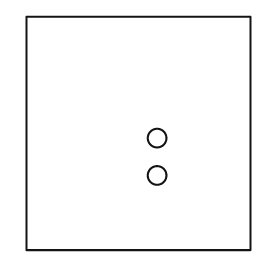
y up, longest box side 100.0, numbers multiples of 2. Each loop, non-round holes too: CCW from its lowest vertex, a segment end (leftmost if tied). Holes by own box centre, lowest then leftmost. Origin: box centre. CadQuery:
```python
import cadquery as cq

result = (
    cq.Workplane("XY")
    .moveTo(-48.0, -50.0)
    .lineTo(48.0, -50.0)
    .lineTo(48.0, 50.0)
    .lineTo(-48.0, 50.0)
    .close()
    .moveTo(8.0, -18.0)
    .circle(4.0)
    .moveTo(8.0, -2.0)
    .circle(4.0)
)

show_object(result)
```